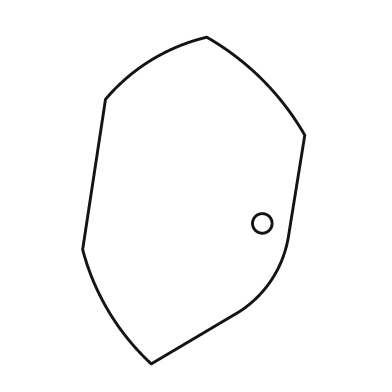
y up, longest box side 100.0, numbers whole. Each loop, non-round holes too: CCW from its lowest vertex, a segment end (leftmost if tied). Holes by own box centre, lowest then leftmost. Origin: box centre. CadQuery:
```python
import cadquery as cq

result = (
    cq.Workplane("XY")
    .moveTo(-13.0, -50.0)
    .lineTo(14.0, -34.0)
    .threePointArc((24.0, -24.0), (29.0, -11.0))
    .lineTo(34.0, 20.0)
    .threePointArc((21.0, 37.0), (4.0, 50.0))
    .threePointArc((-13.0, 43.0), (-27.0, 31.0))
    .lineTo(-34.0, -15.0)
    .threePointArc((-26.0, -34.0), (-13.0, -50.0))
    .close()
    .moveTo(21.0, -7.0)
    .circle(3.0)
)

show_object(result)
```